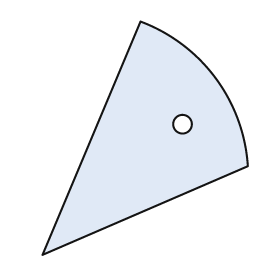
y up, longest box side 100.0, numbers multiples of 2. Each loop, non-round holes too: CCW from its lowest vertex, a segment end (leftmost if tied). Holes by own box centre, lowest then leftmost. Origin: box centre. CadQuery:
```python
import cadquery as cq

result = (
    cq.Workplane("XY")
    .moveTo(-44.0, -50.0)
    .lineTo(44.0, -12.0)
    .threePointArc((30.0, 26.0), (-2.0, 50.0))
    .close()
    .moveTo(16.0, 6.0)
    .circle(4.0)
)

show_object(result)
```